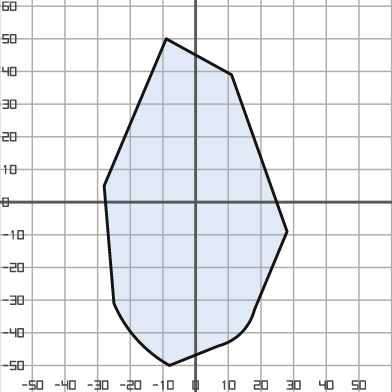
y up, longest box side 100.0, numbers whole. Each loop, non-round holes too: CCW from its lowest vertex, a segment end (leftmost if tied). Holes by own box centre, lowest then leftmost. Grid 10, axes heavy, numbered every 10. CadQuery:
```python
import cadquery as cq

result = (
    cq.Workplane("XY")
    .moveTo(-8.0, -50.0)
    .lineTo(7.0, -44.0)
    .threePointArc((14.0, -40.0), (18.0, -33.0))
    .lineTo(28.0, -9.0)
    .lineTo(11.0, 39.0)
    .lineTo(-9.0, 50.0)
    .lineTo(-28.0, 5.0)
    .lineTo(-25.0, -31.0)
    .threePointArc((-18.0, -42.0), (-8.0, -50.0))
    .close()
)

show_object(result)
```